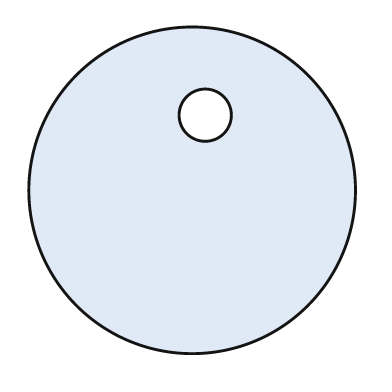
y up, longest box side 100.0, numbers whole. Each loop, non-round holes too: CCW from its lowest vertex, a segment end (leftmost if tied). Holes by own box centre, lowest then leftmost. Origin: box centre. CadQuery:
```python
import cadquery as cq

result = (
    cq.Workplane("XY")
    .moveTo(0.0, 0.0)
    .circle(50.0)
    .moveTo(4.0, 23.0)
    .circle(8.0)
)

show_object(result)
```